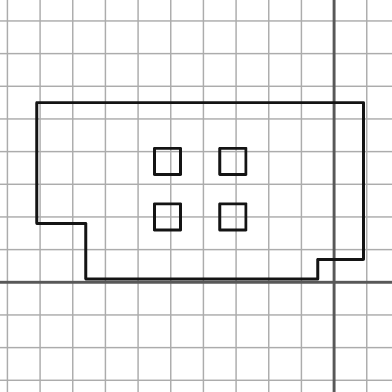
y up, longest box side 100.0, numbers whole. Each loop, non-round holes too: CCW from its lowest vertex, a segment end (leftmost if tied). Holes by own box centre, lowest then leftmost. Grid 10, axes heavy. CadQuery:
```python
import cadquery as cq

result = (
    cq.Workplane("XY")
    .moveTo(-76.0, 1.0)
    .lineTo(-5.0, 1.0)
    .lineTo(-5.0, 7.0)
    .lineTo(9.0, 7.0)
    .lineTo(9.0, 55.0)
    .lineTo(-91.0, 55.0)
    .lineTo(-91.0, 18.0)
    .lineTo(-76.0, 18.0)
    .close()
    .moveTo(-55.0, 16.0)
    .lineTo(-47.0, 16.0)
    .lineTo(-47.0, 24.0)
    .lineTo(-55.0, 24.0)
    .close()
    .moveTo(-35.0, 16.0)
    .lineTo(-27.0, 16.0)
    .lineTo(-27.0, 24.0)
    .lineTo(-35.0, 24.0)
    .close()
    .moveTo(-55.0, 33.0)
    .lineTo(-47.0, 33.0)
    .lineTo(-47.0, 41.0)
    .lineTo(-55.0, 41.0)
    .close()
    .moveTo(-35.0, 33.0)
    .lineTo(-27.0, 33.0)
    .lineTo(-27.0, 41.0)
    .lineTo(-35.0, 41.0)
    .close()
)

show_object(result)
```